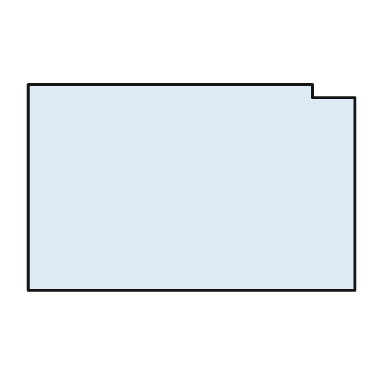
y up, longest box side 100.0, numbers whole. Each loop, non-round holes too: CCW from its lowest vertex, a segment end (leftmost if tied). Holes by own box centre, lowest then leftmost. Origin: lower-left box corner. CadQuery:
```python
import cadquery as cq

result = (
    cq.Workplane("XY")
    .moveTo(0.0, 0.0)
    .lineTo(100.0, 0.0)
    .lineTo(100.0, 59.0)
    .lineTo(87.0, 59.0)
    .lineTo(87.0, 63.0)
    .lineTo(0.0, 63.0)
    .close()
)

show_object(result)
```